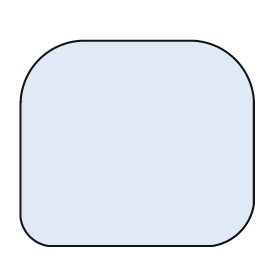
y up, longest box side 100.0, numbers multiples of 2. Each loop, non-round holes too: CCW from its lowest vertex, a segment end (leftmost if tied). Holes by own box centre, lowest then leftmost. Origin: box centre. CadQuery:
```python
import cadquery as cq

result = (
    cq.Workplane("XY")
    .moveTo(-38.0, -44.0)
    .lineTo(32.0, -44.0)
    .threePointArc((44.0, -38.0), (50.0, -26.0))
    .lineTo(50.0, 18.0)
    .threePointArc((42.0, 36.0), (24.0, 44.0))
    .lineTo(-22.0, 44.0)
    .threePointArc((-42.0, 36.0), (-50.0, 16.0))
    .lineTo(-50.0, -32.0)
    .threePointArc((-46.0, -40.0), (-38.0, -44.0))
    .close()
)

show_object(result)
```